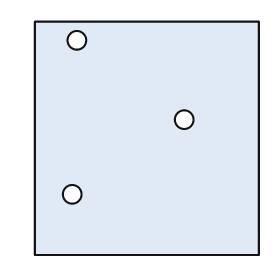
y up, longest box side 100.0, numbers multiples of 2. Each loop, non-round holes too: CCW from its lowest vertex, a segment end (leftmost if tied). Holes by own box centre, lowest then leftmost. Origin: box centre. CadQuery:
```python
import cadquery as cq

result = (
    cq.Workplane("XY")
    .moveTo(-48.0, -50.0)
    .lineTo(48.0, -50.0)
    .lineTo(48.0, 50.0)
    .lineTo(-48.0, 50.0)
    .close()
    .moveTo(-32.0, -24.0)
    .circle(4.0)
    .moveTo(16.0, 8.0)
    .circle(4.0)
    .moveTo(-30.0, 42.0)
    .circle(4.0)
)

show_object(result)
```